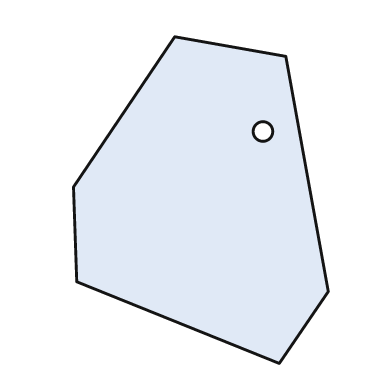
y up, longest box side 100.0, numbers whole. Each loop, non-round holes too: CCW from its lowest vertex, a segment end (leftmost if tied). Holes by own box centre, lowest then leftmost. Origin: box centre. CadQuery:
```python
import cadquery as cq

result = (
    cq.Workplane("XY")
    .moveTo(24.0, -50.0)
    .lineTo(39.0, -28.0)
    .lineTo(26.0, 44.0)
    .lineTo(-8.0, 50.0)
    .lineTo(-39.0, 4.0)
    .lineTo(-38.0, -25.0)
    .close()
    .moveTo(19.0, 21.0)
    .circle(3.0)
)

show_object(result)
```